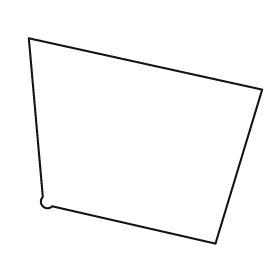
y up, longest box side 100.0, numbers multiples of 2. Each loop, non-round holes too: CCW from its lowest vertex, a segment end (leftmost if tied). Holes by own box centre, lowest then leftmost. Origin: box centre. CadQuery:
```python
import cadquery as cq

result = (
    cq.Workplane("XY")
    .moveTo(30.0, -44.0)
    .lineTo(50.0, 22.0)
    .lineTo(-50.0, 44.0)
    .lineTo(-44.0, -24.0)
    .threePointArc((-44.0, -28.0), (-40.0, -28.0))
    .close()
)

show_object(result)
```